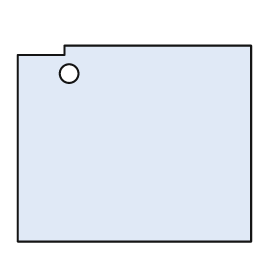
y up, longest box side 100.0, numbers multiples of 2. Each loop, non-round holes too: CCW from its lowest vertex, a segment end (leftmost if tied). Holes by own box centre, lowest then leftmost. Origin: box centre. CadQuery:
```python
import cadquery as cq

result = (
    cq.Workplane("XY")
    .moveTo(-50.0, -42.0)
    .lineTo(50.0, -42.0)
    .lineTo(50.0, 42.0)
    .lineTo(-30.0, 42.0)
    .lineTo(-30.0, 38.0)
    .lineTo(-50.0, 38.0)
    .close()
    .moveTo(-28.0, 30.0)
    .circle(4.0)
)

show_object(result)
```